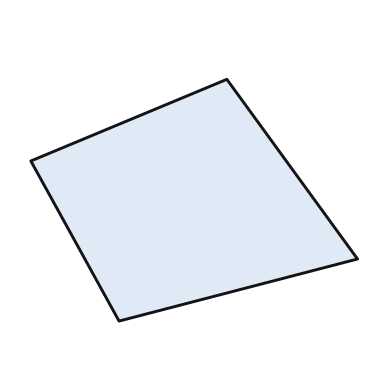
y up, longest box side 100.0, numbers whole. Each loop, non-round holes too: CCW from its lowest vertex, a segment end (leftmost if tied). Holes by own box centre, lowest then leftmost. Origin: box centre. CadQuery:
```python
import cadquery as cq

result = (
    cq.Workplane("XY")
    .moveTo(-23.0, -37.0)
    .lineTo(50.0, -18.0)
    .lineTo(10.0, 37.0)
    .lineTo(-50.0, 12.0)
    .close()
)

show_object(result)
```